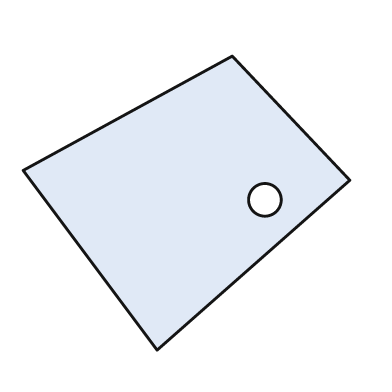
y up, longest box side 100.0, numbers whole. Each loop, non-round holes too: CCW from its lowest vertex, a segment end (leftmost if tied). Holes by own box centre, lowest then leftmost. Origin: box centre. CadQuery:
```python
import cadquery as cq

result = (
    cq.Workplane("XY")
    .moveTo(-9.0, -45.0)
    .lineTo(50.0, 7.0)
    .lineTo(14.0, 45.0)
    .lineTo(-50.0, 10.0)
    .close()
    .moveTo(24.0, 1.0)
    .circle(5.0)
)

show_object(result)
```